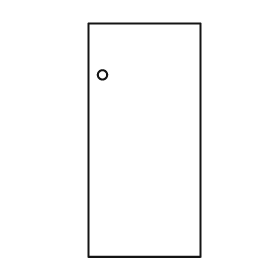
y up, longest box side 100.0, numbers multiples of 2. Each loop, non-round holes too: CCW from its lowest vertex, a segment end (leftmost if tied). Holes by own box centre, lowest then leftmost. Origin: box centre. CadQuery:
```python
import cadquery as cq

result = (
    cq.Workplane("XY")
    .moveTo(-24.0, -50.0)
    .lineTo(24.0, -50.0)
    .lineTo(24.0, 50.0)
    .lineTo(-24.0, 50.0)
    .close()
    .moveTo(-18.0, 28.0)
    .circle(2.0)
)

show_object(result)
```